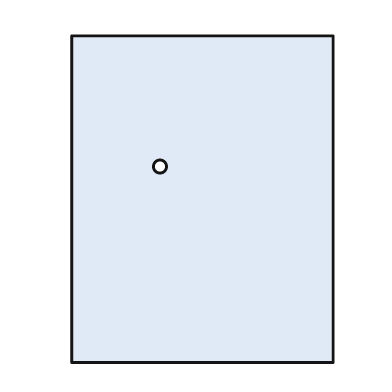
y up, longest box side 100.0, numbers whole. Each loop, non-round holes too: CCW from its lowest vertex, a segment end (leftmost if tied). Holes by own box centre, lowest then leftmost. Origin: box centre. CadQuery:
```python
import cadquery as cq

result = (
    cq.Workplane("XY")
    .moveTo(-40.0, -50.0)
    .lineTo(40.0, -50.0)
    .lineTo(40.0, 50.0)
    .lineTo(-40.0, 50.0)
    .close()
    .moveTo(-13.0, 10.0)
    .circle(2.0)
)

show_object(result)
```